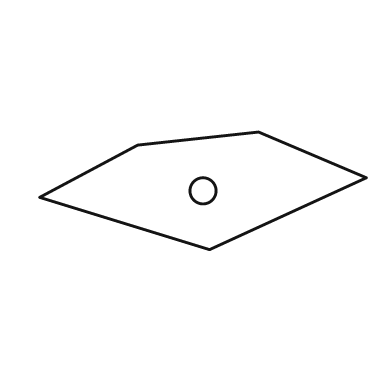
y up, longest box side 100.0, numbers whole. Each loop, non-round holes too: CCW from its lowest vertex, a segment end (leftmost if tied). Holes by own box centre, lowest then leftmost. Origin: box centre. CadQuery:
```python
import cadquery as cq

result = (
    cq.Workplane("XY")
    .moveTo(2.0, -18.0)
    .lineTo(50.0, 4.0)
    .lineTo(17.0, 18.0)
    .lineTo(-20.0, 14.0)
    .lineTo(-50.0, -2.0)
    .close()
    .moveTo(0.0, 0.0)
    .circle(4.0)
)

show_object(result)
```